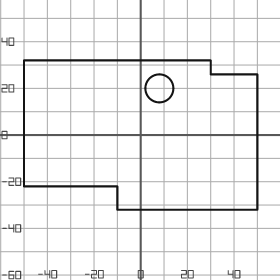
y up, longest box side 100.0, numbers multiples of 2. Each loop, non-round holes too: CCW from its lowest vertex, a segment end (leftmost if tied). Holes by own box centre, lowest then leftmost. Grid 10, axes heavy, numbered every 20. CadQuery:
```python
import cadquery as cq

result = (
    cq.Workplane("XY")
    .moveTo(-10.0, -32.0)
    .lineTo(50.0, -32.0)
    .lineTo(50.0, 26.0)
    .lineTo(30.0, 26.0)
    .lineTo(30.0, 32.0)
    .lineTo(-50.0, 32.0)
    .lineTo(-50.0, -22.0)
    .lineTo(-10.0, -22.0)
    .close()
    .moveTo(8.0, 20.0)
    .circle(6.0)
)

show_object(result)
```